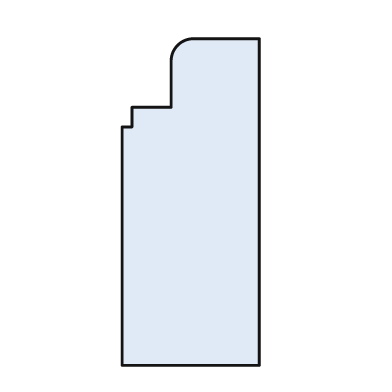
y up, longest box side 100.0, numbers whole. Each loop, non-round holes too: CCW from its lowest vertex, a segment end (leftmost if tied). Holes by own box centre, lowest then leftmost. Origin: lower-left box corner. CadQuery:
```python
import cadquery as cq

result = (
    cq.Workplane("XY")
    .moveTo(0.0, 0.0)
    .lineTo(42.0, 0.0)
    .lineTo(42.0, 100.0)
    .lineTo(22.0, 100.0)
    .threePointArc((17.0, 98.0), (15.0, 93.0))
    .lineTo(15.0, 79.0)
    .lineTo(3.0, 79.0)
    .lineTo(3.0, 73.0)
    .lineTo(0.0, 73.0)
    .close()
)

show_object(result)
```